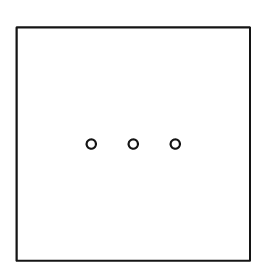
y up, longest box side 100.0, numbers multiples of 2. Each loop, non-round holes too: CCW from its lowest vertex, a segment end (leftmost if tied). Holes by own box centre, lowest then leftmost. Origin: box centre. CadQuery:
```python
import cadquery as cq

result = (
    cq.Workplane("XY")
    .moveTo(-50.0, -50.0)
    .lineTo(50.0, -50.0)
    .lineTo(50.0, 50.0)
    .lineTo(-50.0, 50.0)
    .close()
    .moveTo(-18.0, 0.0)
    .circle(2.0)
    .moveTo(0.0, 0.0)
    .circle(2.0)
    .moveTo(18.0, 0.0)
    .circle(2.0)
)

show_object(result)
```